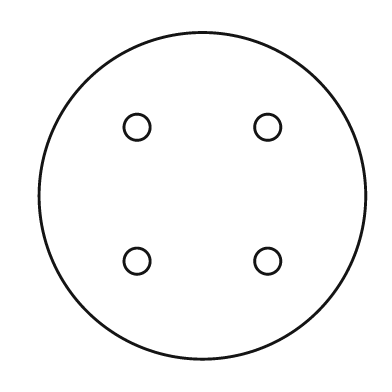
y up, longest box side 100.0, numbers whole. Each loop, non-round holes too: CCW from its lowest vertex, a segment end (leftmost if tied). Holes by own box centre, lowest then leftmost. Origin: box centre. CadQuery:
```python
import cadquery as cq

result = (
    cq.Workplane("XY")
    .moveTo(0.0, 0.0)
    .circle(50.0)
    .moveTo(-20.0, -20.0)
    .circle(4.0)
    .moveTo(20.0, -20.0)
    .circle(4.0)
    .moveTo(-20.0, 21.0)
    .circle(4.0)
    .moveTo(20.0, 21.0)
    .circle(4.0)
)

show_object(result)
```